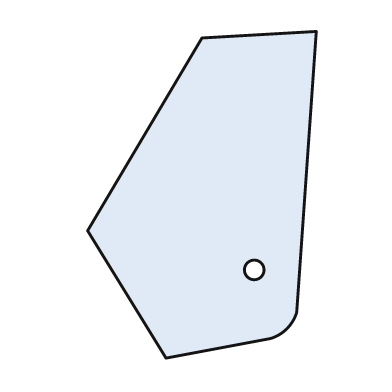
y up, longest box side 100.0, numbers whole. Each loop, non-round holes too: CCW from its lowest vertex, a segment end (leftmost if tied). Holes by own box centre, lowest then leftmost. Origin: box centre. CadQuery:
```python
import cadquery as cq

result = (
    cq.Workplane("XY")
    .moveTo(-11.0, -50.0)
    .lineTo(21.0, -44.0)
    .threePointArc((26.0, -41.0), (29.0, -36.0))
    .lineTo(35.0, 50.0)
    .lineTo(0.0, 48.0)
    .lineTo(-35.0, -11.0)
    .close()
    .moveTo(16.0, -23.0)
    .circle(3.0)
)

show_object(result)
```